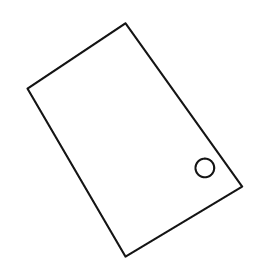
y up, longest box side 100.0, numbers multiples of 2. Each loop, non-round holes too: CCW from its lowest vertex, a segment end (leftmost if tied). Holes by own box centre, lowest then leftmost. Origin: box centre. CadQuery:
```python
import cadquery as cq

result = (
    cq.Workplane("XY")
    .moveTo(-4.0, -50.0)
    .lineTo(46.0, -20.0)
    .lineTo(-4.0, 50.0)
    .lineTo(-46.0, 22.0)
    .close()
    .moveTo(30.0, -12.0)
    .circle(4.0)
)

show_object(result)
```